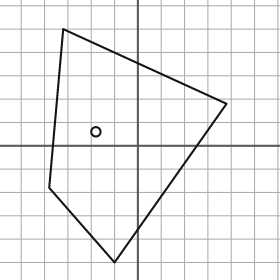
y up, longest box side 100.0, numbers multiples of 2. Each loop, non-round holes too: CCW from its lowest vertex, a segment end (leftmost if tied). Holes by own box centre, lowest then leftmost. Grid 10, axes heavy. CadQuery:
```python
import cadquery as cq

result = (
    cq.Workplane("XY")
    .moveTo(-10.0, -50.0)
    .lineTo(38.0, 18.0)
    .lineTo(-32.0, 50.0)
    .lineTo(-38.0, -18.0)
    .close()
    .moveTo(-18.0, 6.0)
    .circle(2.0)
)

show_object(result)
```